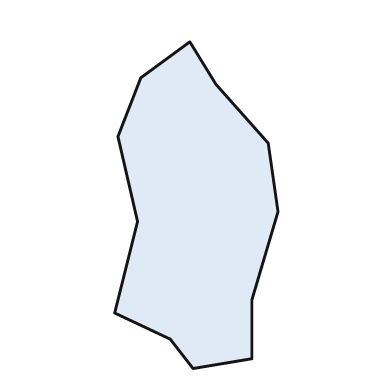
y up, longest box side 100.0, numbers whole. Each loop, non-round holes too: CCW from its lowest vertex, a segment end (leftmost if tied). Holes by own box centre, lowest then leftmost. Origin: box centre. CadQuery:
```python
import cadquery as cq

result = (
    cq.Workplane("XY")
    .moveTo(-1.0, -50.0)
    .lineTo(17.0, -47.0)
    .lineTo(17.0, -29.0)
    .lineTo(25.0, -2.0)
    .lineTo(22.0, 19.0)
    .lineTo(6.0, 37.0)
    .lineTo(-2.0, 50.0)
    .lineTo(-17.0, 39.0)
    .lineTo(-24.0, 21.0)
    .lineTo(-18.0, -5.0)
    .lineTo(-25.0, -33.0)
    .lineTo(-8.0, -41.0)
    .close()
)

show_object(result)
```